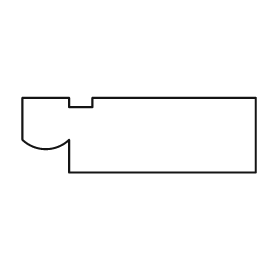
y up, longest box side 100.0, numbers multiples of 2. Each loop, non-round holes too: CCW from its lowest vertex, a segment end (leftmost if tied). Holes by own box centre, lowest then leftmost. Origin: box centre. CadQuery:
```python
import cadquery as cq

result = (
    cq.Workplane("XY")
    .moveTo(-30.0, -16.0)
    .lineTo(50.0, -16.0)
    .lineTo(50.0, 16.0)
    .lineTo(-20.0, 16.0)
    .lineTo(-20.0, 12.0)
    .lineTo(-30.0, 12.0)
    .lineTo(-30.0, 16.0)
    .lineTo(-50.0, 16.0)
    .lineTo(-50.0, -2.0)
    .threePointArc((-40.0, -6.0), (-30.0, -2.0))
    .close()
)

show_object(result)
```